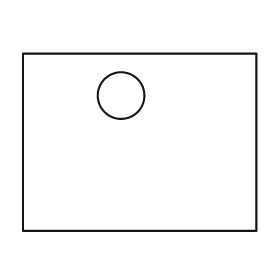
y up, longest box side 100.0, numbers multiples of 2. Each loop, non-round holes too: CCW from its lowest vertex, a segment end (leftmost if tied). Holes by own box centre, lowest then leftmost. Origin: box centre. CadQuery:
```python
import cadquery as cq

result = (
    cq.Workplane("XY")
    .moveTo(-50.0, -38.0)
    .lineTo(50.0, -38.0)
    .lineTo(50.0, 38.0)
    .lineTo(-50.0, 38.0)
    .close()
    .moveTo(-8.0, 20.0)
    .circle(10.0)
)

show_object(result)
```